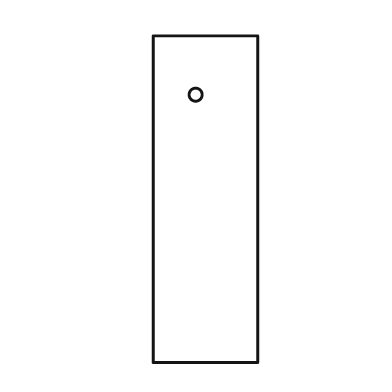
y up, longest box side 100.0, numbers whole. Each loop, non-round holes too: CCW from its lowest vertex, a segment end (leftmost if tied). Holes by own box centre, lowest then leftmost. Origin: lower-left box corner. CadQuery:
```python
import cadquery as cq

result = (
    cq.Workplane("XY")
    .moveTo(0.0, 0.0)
    .lineTo(32.0, 0.0)
    .lineTo(32.0, 100.0)
    .lineTo(0.0, 100.0)
    .close()
    .moveTo(13.0, 82.0)
    .circle(2.0)
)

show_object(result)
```